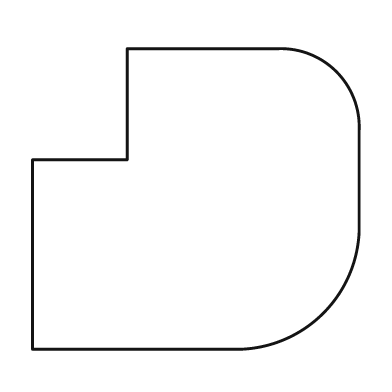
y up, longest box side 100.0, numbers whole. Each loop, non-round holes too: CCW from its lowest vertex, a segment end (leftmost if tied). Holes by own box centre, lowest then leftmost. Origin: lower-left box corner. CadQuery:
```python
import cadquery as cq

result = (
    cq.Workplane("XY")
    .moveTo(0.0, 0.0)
    .lineTo(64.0, 0.0)
    .threePointArc((89.0, 11.0), (100.0, 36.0))
    .lineTo(100.0, 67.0)
    .threePointArc((93.0, 85.0), (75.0, 92.0))
    .lineTo(29.0, 92.0)
    .lineTo(29.0, 58.0)
    .lineTo(0.0, 58.0)
    .close()
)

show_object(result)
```